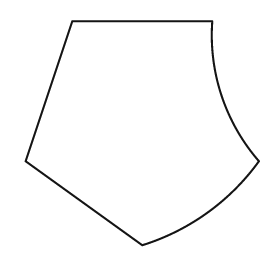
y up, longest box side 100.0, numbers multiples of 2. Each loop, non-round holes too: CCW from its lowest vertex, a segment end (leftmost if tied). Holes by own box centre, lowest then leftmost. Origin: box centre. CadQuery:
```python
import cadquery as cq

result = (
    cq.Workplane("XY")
    .moveTo(0.0, -48.0)
    .threePointArc((28.0, -34.0), (50.0, -12.0))
    .threePointArc((34.0, 16.0), (30.0, 48.0))
    .lineTo(-30.0, 48.0)
    .lineTo(-50.0, -12.0)
    .close()
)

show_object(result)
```